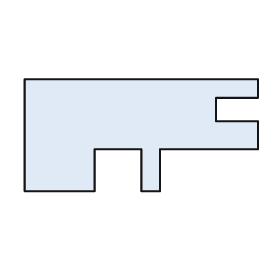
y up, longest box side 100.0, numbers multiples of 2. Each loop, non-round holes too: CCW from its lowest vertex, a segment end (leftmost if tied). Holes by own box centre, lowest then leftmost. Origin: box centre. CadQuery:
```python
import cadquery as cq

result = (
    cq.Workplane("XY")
    .moveTo(-50.0, -24.0)
    .lineTo(-20.0, -24.0)
    .lineTo(-20.0, -6.0)
    .lineTo(0.0, -6.0)
    .lineTo(0.0, -24.0)
    .lineTo(8.0, -24.0)
    .lineTo(8.0, -6.0)
    .lineTo(50.0, -6.0)
    .lineTo(50.0, 6.0)
    .lineTo(32.0, 6.0)
    .lineTo(32.0, 16.0)
    .lineTo(50.0, 16.0)
    .lineTo(50.0, 24.0)
    .lineTo(-50.0, 24.0)
    .close()
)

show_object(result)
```